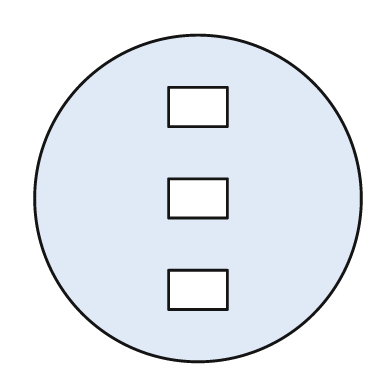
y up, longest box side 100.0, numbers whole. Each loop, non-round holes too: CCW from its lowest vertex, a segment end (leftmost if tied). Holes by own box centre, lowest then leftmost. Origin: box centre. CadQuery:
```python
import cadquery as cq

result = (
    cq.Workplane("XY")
    .moveTo(0.0, 0.0)
    .circle(50.0)
    .moveTo(-9.0, -34.0)
    .lineTo(9.0, -34.0)
    .lineTo(9.0, -22.0)
    .lineTo(-9.0, -22.0)
    .close()
    .moveTo(-9.0, -6.0)
    .lineTo(9.0, -6.0)
    .lineTo(9.0, 6.0)
    .lineTo(-9.0, 6.0)
    .close()
    .moveTo(-9.0, 22.0)
    .lineTo(9.0, 22.0)
    .lineTo(9.0, 34.0)
    .lineTo(-9.0, 34.0)
    .close()
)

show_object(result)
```